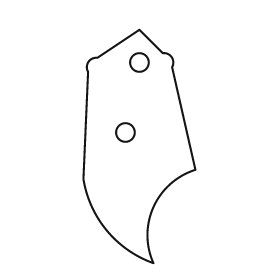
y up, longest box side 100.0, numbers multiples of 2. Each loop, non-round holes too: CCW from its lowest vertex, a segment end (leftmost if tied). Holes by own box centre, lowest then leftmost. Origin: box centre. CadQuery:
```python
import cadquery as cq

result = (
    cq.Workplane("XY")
    .moveTo(6.0, -50.0)
    .threePointArc((6.0, -26.0), (24.0, -10.0))
    .lineTo(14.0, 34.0)
    .threePointArc((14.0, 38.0), (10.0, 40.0))
    .lineTo(0.0, 50.0)
    .lineTo(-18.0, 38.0)
    .threePointArc((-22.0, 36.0), (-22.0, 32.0))
    .lineTo(-24.0, -14.0)
    .threePointArc((-14.0, -36.0), (6.0, -50.0))
    .close()
    .moveTo(-6.0, 6.0)
    .circle(4.0)
    .moveTo(0.0, 36.0)
    .circle(4.0)
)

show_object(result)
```